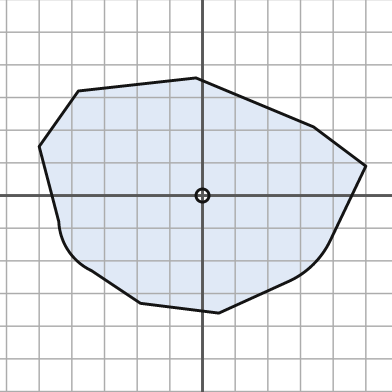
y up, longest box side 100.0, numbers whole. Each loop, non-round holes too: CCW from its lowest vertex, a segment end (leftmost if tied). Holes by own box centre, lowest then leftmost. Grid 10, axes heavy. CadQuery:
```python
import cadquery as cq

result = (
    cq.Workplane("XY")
    .moveTo(5.0, -36.0)
    .lineTo(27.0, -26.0)
    .threePointArc((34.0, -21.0), (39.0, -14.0))
    .lineTo(50.0, 9.0)
    .lineTo(34.0, 21.0)
    .lineTo(-2.0, 36.0)
    .lineTo(-38.0, 32.0)
    .lineTo(-50.0, 15.0)
    .lineTo(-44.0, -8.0)
    .threePointArc((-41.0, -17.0), (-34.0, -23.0))
    .lineTo(-19.0, -33.0)
    .close()
    .moveTo(0.0, 0.0)
    .circle(2.0)
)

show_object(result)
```